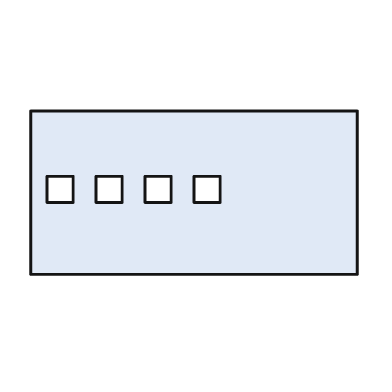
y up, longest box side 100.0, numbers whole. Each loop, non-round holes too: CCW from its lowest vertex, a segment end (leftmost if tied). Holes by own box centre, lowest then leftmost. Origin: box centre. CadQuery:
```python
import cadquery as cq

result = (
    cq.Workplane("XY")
    .moveTo(-50.0, -25.0)
    .lineTo(50.0, -25.0)
    .lineTo(50.0, 25.0)
    .lineTo(-50.0, 25.0)
    .close()
    .moveTo(-45.0, -3.0)
    .lineTo(-37.0, -3.0)
    .lineTo(-37.0, 5.0)
    .lineTo(-45.0, 5.0)
    .close()
    .moveTo(-30.0, -3.0)
    .lineTo(-22.0, -3.0)
    .lineTo(-22.0, 5.0)
    .lineTo(-30.0, 5.0)
    .close()
    .moveTo(-15.0, -3.0)
    .lineTo(-7.0, -3.0)
    .lineTo(-7.0, 5.0)
    .lineTo(-15.0, 5.0)
    .close()
    .moveTo(0.0, -3.0)
    .lineTo(8.0, -3.0)
    .lineTo(8.0, 5.0)
    .lineTo(0.0, 5.0)
    .close()
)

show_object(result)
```